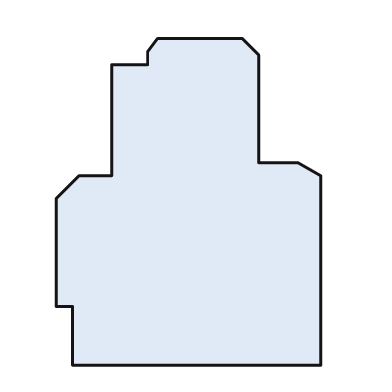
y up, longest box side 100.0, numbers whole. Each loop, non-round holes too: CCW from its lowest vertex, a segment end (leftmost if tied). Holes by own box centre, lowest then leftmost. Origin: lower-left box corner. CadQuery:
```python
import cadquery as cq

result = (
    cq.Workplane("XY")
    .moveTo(5.0, 0.0)
    .lineTo(81.0, 0.0)
    .lineTo(81.0, 58.0)
    .lineTo(74.0, 62.0)
    .lineTo(62.0, 62.0)
    .lineTo(62.0, 95.0)
    .lineTo(57.0, 100.0)
    .lineTo(31.0, 100.0)
    .lineTo(28.0, 96.0)
    .lineTo(28.0, 92.0)
    .lineTo(17.0, 92.0)
    .lineTo(17.0, 58.0)
    .lineTo(7.0, 58.0)
    .lineTo(0.0, 51.0)
    .lineTo(0.0, 18.0)
    .lineTo(5.0, 18.0)
    .close()
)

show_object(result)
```